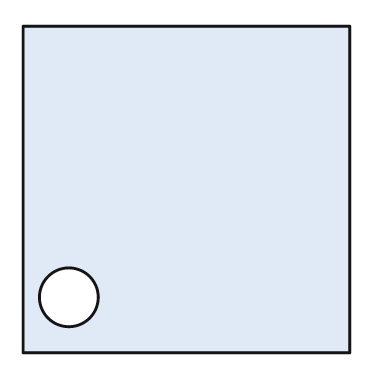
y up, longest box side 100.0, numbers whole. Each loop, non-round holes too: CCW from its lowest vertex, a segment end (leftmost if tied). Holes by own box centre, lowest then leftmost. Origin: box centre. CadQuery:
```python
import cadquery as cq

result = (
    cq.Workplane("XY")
    .moveTo(-50.0, -50.0)
    .lineTo(50.0, -50.0)
    .lineTo(50.0, 50.0)
    .lineTo(-50.0, 50.0)
    .close()
    .moveTo(-36.0, -33.0)
    .circle(9.0)
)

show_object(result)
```